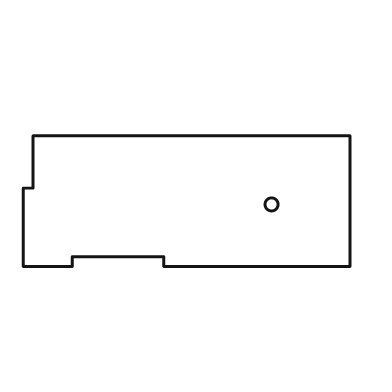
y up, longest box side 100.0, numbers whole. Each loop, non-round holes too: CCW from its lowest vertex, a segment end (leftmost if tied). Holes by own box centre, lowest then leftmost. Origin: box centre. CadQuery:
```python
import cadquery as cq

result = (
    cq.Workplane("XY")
    .moveTo(-50.0, -20.0)
    .lineTo(-35.0, -20.0)
    .lineTo(-35.0, -17.0)
    .lineTo(-7.0, -17.0)
    .lineTo(-7.0, -20.0)
    .lineTo(50.0, -20.0)
    .lineTo(50.0, 20.0)
    .lineTo(-47.0, 20.0)
    .lineTo(-47.0, 4.0)
    .lineTo(-50.0, 4.0)
    .close()
    .moveTo(26.0, -1.0)
    .circle(2.0)
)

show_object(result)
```